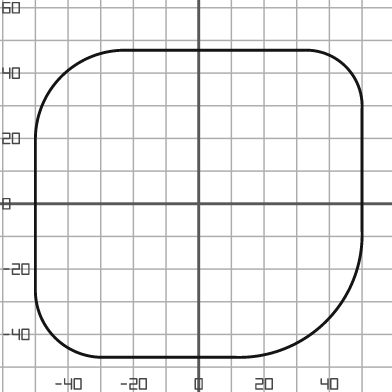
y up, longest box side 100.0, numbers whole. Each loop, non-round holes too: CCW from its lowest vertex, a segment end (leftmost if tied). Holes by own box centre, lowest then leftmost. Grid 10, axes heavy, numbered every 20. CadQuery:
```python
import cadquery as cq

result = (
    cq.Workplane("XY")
    .moveTo(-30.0, -47.0)
    .lineTo(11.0, -47.0)
    .threePointArc((39.0, -36.0), (50.0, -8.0))
    .lineTo(50.0, 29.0)
    .threePointArc((45.0, 42.0), (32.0, 47.0))
    .lineTo(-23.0, 47.0)
    .threePointArc((-42.0, 39.0), (-50.0, 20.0))
    .lineTo(-50.0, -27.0)
    .threePointArc((-44.0, -41.0), (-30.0, -47.0))
    .close()
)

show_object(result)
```